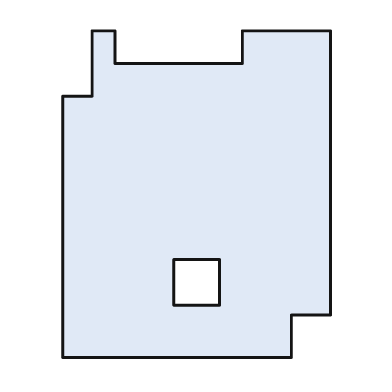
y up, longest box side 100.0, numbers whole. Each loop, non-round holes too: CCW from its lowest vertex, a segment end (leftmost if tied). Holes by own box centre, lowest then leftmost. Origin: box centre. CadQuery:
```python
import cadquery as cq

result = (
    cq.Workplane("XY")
    .moveTo(-41.0, -50.0)
    .lineTo(29.0, -50.0)
    .lineTo(29.0, -37.0)
    .lineTo(41.0, -37.0)
    .lineTo(41.0, 50.0)
    .lineTo(14.0, 50.0)
    .lineTo(14.0, 40.0)
    .lineTo(-25.0, 40.0)
    .lineTo(-25.0, 50.0)
    .lineTo(-32.0, 50.0)
    .lineTo(-32.0, 30.0)
    .lineTo(-41.0, 30.0)
    .close()
    .moveTo(-7.0, -34.0)
    .lineTo(7.0, -34.0)
    .lineTo(7.0, -20.0)
    .lineTo(-7.0, -20.0)
    .close()
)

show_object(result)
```